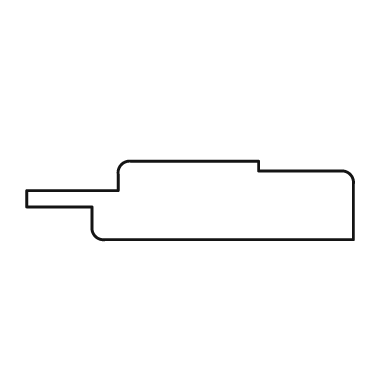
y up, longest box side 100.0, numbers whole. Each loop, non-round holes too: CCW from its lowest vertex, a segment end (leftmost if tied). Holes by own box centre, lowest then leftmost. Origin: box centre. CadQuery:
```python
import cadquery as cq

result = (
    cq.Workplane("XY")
    .moveTo(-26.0, -12.0)
    .lineTo(50.0, -12.0)
    .lineTo(50.0, 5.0)
    .threePointArc((49.0, 8.0), (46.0, 9.0))
    .lineTo(21.0, 9.0)
    .lineTo(21.0, 12.0)
    .lineTo(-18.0, 12.0)
    .threePointArc((-21.0, 11.0), (-22.0, 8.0))
    .lineTo(-22.0, 3.0)
    .lineTo(-50.0, 3.0)
    .lineTo(-50.0, -2.0)
    .lineTo(-30.0, -2.0)
    .lineTo(-30.0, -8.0)
    .threePointArc((-29.0, -11.0), (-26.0, -12.0))
    .close()
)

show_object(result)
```